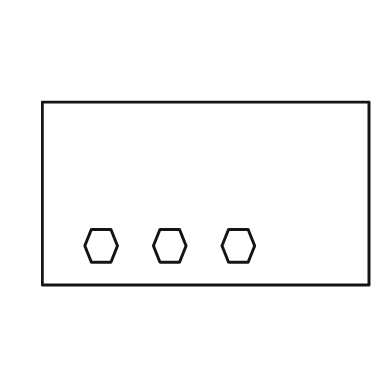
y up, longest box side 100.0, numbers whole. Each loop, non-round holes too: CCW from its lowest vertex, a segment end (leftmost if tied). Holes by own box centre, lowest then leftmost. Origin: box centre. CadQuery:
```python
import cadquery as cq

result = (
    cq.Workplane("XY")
    .moveTo(-50.0, -28.0)
    .lineTo(50.0, -28.0)
    .lineTo(50.0, 28.0)
    .lineTo(-50.0, 28.0)
    .close()
    .moveTo(-35.0, -21.0)
    .lineTo(-29.0, -21.0)
    .lineTo(-27.0, -16.0)
    .lineTo(-29.0, -11.0)
    .lineTo(-35.0, -11.0)
    .lineTo(-37.0, -16.0)
    .close()
    .moveTo(-14.0, -21.0)
    .lineTo(-8.0, -21.0)
    .lineTo(-6.0, -16.0)
    .lineTo(-8.0, -11.0)
    .lineTo(-14.0, -11.0)
    .lineTo(-16.0, -16.0)
    .close()
    .moveTo(7.0, -21.0)
    .lineTo(13.0, -21.0)
    .lineTo(15.0, -16.0)
    .lineTo(13.0, -11.0)
    .lineTo(7.0, -11.0)
    .lineTo(5.0, -16.0)
    .close()
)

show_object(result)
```